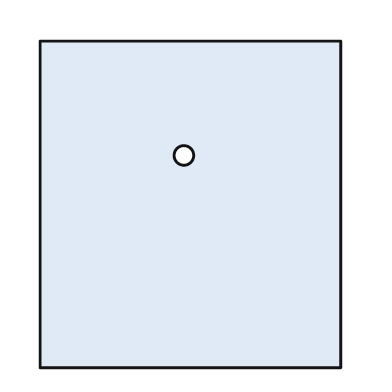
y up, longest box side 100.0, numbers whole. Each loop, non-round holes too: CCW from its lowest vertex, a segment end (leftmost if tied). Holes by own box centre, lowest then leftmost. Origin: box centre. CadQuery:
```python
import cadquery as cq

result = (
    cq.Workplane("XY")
    .moveTo(-46.0, -50.0)
    .lineTo(46.0, -50.0)
    .lineTo(46.0, 50.0)
    .lineTo(-46.0, 50.0)
    .close()
    .moveTo(-2.0, 15.0)
    .circle(3.0)
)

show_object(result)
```